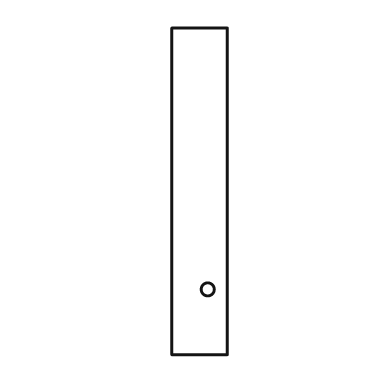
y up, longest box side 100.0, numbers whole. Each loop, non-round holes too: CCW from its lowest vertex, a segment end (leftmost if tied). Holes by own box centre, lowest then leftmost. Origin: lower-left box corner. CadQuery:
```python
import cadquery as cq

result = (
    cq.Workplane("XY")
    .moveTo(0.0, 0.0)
    .lineTo(17.0, 0.0)
    .lineTo(17.0, 100.0)
    .lineTo(0.0, 100.0)
    .close()
    .moveTo(11.0, 20.0)
    .circle(2.0)
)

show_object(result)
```